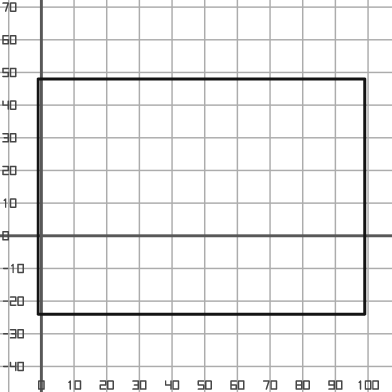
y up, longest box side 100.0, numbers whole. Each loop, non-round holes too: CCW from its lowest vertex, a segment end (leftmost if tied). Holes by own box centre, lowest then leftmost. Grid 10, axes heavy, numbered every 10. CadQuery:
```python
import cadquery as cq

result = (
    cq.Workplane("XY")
    .moveTo(-1.0, -24.0)
    .lineTo(99.0, -24.0)
    .lineTo(99.0, 48.0)
    .lineTo(-1.0, 48.0)
    .close()
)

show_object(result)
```